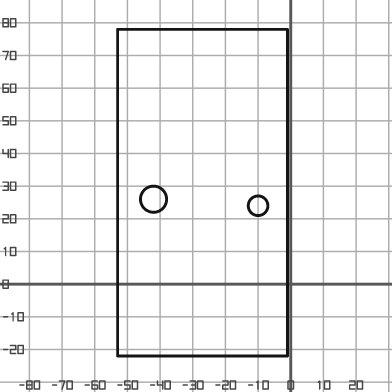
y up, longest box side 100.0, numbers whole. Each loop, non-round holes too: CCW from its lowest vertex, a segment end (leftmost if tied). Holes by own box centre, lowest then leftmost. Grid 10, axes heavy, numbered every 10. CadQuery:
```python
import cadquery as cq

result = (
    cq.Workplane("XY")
    .moveTo(-53.0, -22.0)
    .lineTo(-1.0, -22.0)
    .lineTo(-1.0, 78.0)
    .lineTo(-53.0, 78.0)
    .close()
    .moveTo(-10.0, 24.0)
    .circle(3.0)
    .moveTo(-42.0, 26.0)
    .circle(4.0)
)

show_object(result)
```